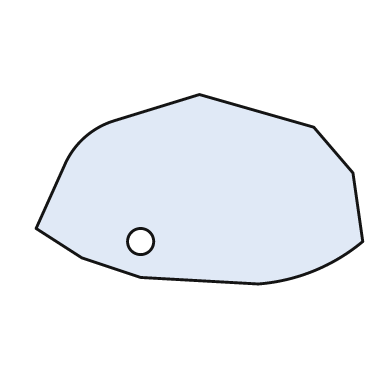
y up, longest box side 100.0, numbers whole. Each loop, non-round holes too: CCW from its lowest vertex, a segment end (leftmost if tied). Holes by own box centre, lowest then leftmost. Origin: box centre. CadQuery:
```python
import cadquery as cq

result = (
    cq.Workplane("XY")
    .moveTo(18.0, -29.0)
    .threePointArc((35.0, -25.0), (50.0, -16.0))
    .lineTo(47.0, 5.0)
    .lineTo(35.0, 19.0)
    .lineTo(0.0, 29.0)
    .lineTo(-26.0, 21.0)
    .threePointArc((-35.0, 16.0), (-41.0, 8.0))
    .lineTo(-50.0, -12.0)
    .lineTo(-36.0, -21.0)
    .lineTo(-18.0, -27.0)
    .close()
    .moveTo(-18.0, -16.0)
    .circle(4.0)
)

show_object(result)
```